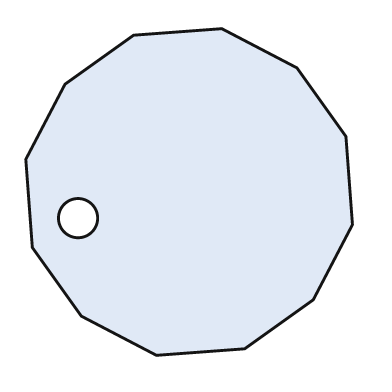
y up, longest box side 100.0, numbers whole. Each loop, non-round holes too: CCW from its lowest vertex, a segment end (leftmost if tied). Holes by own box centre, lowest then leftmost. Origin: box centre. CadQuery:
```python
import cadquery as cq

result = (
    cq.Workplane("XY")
    .moveTo(-10.0, -50.0)
    .lineTo(17.0, -48.0)
    .lineTo(38.0, -33.0)
    .lineTo(50.0, -10.0)
    .lineTo(48.0, 17.0)
    .lineTo(33.0, 38.0)
    .lineTo(10.0, 50.0)
    .lineTo(-17.0, 48.0)
    .lineTo(-38.0, 33.0)
    .lineTo(-50.0, 10.0)
    .lineTo(-48.0, -17.0)
    .lineTo(-33.0, -38.0)
    .close()
    .moveTo(-34.0, -8.0)
    .circle(6.0)
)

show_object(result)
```